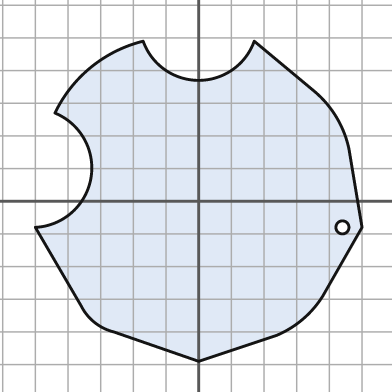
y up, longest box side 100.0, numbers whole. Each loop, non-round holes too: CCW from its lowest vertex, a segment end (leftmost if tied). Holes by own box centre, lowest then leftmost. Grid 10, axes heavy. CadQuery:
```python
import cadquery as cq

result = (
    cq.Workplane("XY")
    .moveTo(0.0, -49.0)
    .lineTo(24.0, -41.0)
    .threePointArc((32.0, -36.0), (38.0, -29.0))
    .lineTo(50.0, -8.0)
    .lineTo(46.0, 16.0)
    .threePointArc((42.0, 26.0), (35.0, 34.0))
    .lineTo(17.0, 49.0)
    .threePointArc((0.0, 37.0), (-17.0, 49.0))
    .threePointArc((-33.0, 41.0), (-44.0, 27.0))
    .threePointArc((-33.0, 7.0), (-50.0, -8.0))
    .lineTo(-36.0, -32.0)
    .threePointArc((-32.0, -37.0), (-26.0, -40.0))
    .close()
    .moveTo(44.0, -8.0)
    .circle(2.0)
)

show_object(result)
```